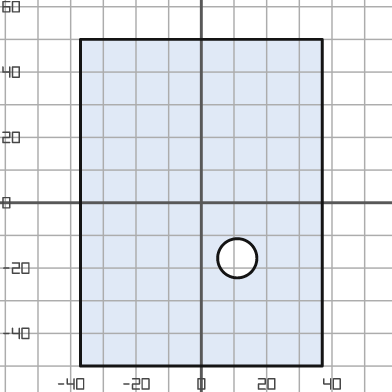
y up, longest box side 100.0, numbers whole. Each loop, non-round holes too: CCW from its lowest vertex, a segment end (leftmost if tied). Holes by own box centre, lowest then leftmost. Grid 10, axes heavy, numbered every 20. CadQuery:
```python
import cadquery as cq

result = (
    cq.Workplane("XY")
    .moveTo(-37.0, -50.0)
    .lineTo(37.0, -50.0)
    .lineTo(37.0, 50.0)
    .lineTo(-37.0, 50.0)
    .close()
    .moveTo(11.0, -17.0)
    .circle(6.0)
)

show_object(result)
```